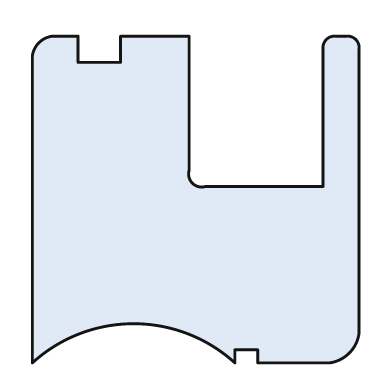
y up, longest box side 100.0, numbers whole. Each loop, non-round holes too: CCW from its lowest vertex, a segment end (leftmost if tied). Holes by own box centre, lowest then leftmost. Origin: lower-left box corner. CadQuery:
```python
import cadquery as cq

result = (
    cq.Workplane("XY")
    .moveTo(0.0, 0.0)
    .threePointArc((31.0, 12.0), (62.0, 0.0))
    .lineTo(62.0, 4.0)
    .lineTo(69.0, 4.0)
    .lineTo(69.0, 0.0)
    .lineTo(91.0, 0.0)
    .threePointArc((97.0, 3.0), (100.0, 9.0))
    .lineTo(100.0, 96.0)
    .threePointArc((99.0, 99.0), (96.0, 100.0))
    .lineTo(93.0, 100.0)
    .threePointArc((90.0, 99.0), (89.0, 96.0))
    .lineTo(89.0, 54.0)
    .lineTo(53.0, 54.0)
    .threePointArc((49.0, 55.0), (48.0, 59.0))
    .lineTo(48.0, 100.0)
    .lineTo(27.0, 100.0)
    .lineTo(27.0, 92.0)
    .lineTo(14.0, 92.0)
    .lineTo(14.0, 100.0)
    .lineTo(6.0, 100.0)
    .threePointArc((2.0, 98.0), (0.0, 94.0))
    .close()
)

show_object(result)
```